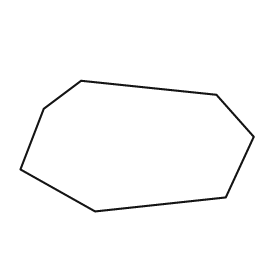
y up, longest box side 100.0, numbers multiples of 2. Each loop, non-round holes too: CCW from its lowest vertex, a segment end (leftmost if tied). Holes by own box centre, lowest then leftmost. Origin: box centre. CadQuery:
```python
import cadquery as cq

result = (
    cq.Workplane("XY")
    .moveTo(-18.0, -28.0)
    .lineTo(38.0, -22.0)
    .lineTo(50.0, 4.0)
    .lineTo(34.0, 22.0)
    .lineTo(-24.0, 28.0)
    .lineTo(-40.0, 16.0)
    .lineTo(-50.0, -10.0)
    .close()
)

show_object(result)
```